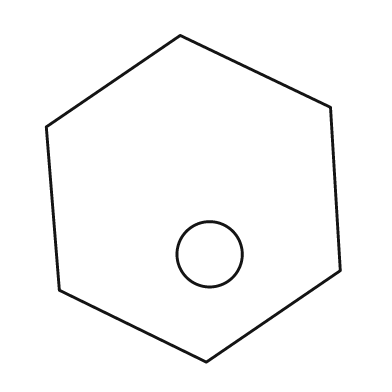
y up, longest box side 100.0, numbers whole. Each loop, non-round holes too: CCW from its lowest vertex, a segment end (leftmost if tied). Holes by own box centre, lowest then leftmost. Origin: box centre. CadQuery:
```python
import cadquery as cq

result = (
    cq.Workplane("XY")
    .moveTo(4.0, -50.0)
    .lineTo(45.0, -22.0)
    .lineTo(42.0, 28.0)
    .lineTo(-4.0, 50.0)
    .lineTo(-45.0, 22.0)
    .lineTo(-41.0, -28.0)
    .close()
    .moveTo(5.0, -17.0)
    .circle(10.0)
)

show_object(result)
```